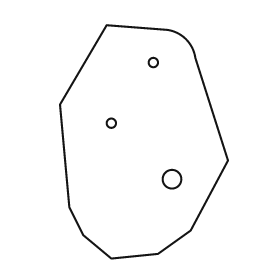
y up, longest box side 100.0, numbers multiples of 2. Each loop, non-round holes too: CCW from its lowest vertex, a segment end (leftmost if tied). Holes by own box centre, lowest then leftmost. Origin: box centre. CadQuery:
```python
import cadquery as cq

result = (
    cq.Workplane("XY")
    .moveTo(-14.0, -50.0)
    .lineTo(6.0, -48.0)
    .lineTo(20.0, -38.0)
    .lineTo(36.0, -8.0)
    .lineTo(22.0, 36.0)
    .threePointArc((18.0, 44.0), (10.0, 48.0))
    .lineTo(-16.0, 50.0)
    .lineTo(-36.0, 16.0)
    .lineTo(-32.0, -28.0)
    .lineTo(-26.0, -40.0)
    .close()
    .moveTo(12.0, -16.0)
    .circle(4.0)
    .moveTo(-14.0, 8.0)
    .circle(2.0)
    .moveTo(4.0, 34.0)
    .circle(2.0)
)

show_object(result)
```